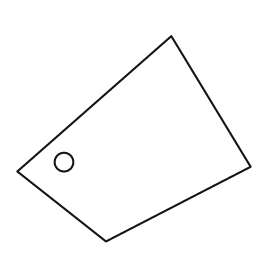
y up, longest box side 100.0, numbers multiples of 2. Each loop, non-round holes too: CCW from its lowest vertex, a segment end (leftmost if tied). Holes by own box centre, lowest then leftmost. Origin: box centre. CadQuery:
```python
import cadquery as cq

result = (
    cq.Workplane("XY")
    .moveTo(-12.0, -44.0)
    .lineTo(50.0, -12.0)
    .lineTo(16.0, 44.0)
    .lineTo(-50.0, -14.0)
    .close()
    .moveTo(-30.0, -10.0)
    .circle(4.0)
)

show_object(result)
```